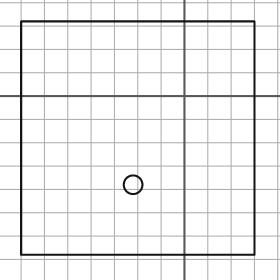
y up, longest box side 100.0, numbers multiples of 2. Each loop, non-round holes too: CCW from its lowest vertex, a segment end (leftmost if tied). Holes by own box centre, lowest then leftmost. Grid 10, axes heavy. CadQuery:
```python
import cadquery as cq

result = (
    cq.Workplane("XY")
    .moveTo(-70.0, -68.0)
    .lineTo(30.0, -68.0)
    .lineTo(30.0, 32.0)
    .lineTo(-70.0, 32.0)
    .close()
    .moveTo(-22.0, -38.0)
    .circle(4.0)
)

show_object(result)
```